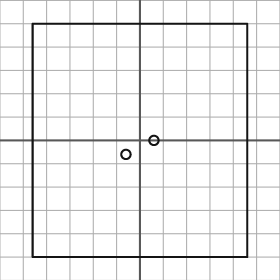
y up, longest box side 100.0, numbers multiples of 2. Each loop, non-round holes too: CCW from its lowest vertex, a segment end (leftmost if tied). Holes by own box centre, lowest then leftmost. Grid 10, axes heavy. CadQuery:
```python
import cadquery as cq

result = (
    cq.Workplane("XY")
    .moveTo(-46.0, -50.0)
    .lineTo(46.0, -50.0)
    .lineTo(46.0, 50.0)
    .lineTo(-46.0, 50.0)
    .close()
    .moveTo(-6.0, -6.0)
    .circle(2.0)
    .moveTo(6.0, 0.0)
    .circle(2.0)
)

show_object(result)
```